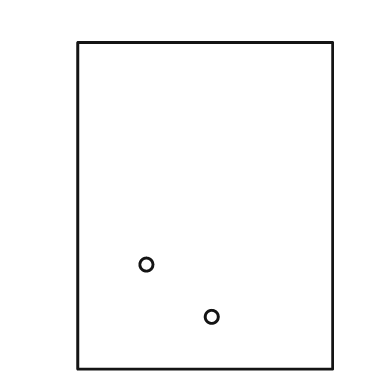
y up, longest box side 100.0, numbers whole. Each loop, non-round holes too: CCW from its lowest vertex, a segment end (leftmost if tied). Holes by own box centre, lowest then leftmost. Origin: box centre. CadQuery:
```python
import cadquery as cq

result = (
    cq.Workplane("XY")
    .moveTo(-39.0, -50.0)
    .lineTo(39.0, -50.0)
    .lineTo(39.0, 50.0)
    .lineTo(-39.0, 50.0)
    .close()
    .moveTo(2.0, -34.0)
    .circle(2.0)
    .moveTo(-18.0, -18.0)
    .circle(2.0)
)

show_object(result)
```